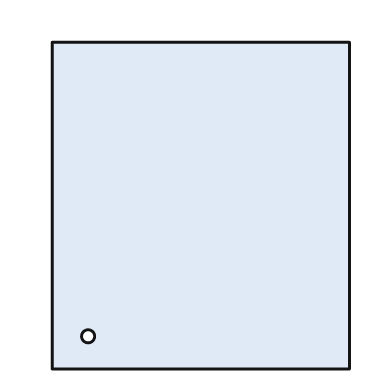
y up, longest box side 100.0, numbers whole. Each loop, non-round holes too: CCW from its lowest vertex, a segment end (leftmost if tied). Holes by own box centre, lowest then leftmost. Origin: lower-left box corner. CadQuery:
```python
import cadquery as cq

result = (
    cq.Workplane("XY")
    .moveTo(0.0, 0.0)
    .lineTo(91.0, 0.0)
    .lineTo(91.0, 100.0)
    .lineTo(0.0, 100.0)
    .close()
    .moveTo(11.0, 10.0)
    .circle(2.0)
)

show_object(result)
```